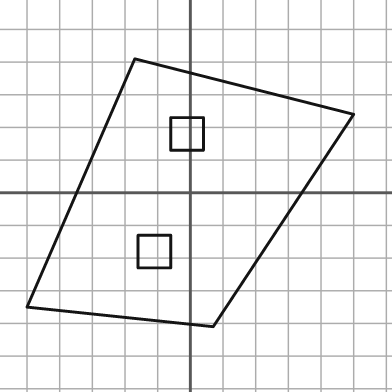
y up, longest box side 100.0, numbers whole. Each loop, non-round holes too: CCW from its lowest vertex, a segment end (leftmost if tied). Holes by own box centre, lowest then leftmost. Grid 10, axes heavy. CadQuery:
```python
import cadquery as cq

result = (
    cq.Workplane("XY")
    .moveTo(7.0, -41.0)
    .lineTo(50.0, 24.0)
    .lineTo(-17.0, 41.0)
    .lineTo(-50.0, -35.0)
    .close()
    .moveTo(-16.0, -23.0)
    .lineTo(-6.0, -23.0)
    .lineTo(-6.0, -13.0)
    .lineTo(-16.0, -13.0)
    .close()
    .moveTo(-6.0, 13.0)
    .lineTo(4.0, 13.0)
    .lineTo(4.0, 23.0)
    .lineTo(-6.0, 23.0)
    .close()
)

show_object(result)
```